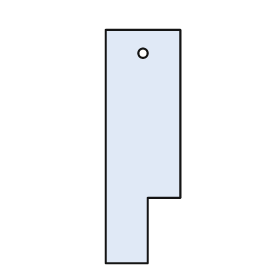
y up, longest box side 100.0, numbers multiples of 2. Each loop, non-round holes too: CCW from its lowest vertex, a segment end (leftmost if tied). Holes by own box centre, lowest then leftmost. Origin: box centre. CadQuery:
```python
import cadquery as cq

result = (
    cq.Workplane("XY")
    .moveTo(-16.0, -50.0)
    .lineTo(2.0, -50.0)
    .lineTo(2.0, -22.0)
    .lineTo(16.0, -22.0)
    .lineTo(16.0, 50.0)
    .lineTo(-16.0, 50.0)
    .close()
    .moveTo(0.0, 40.0)
    .circle(2.0)
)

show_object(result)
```